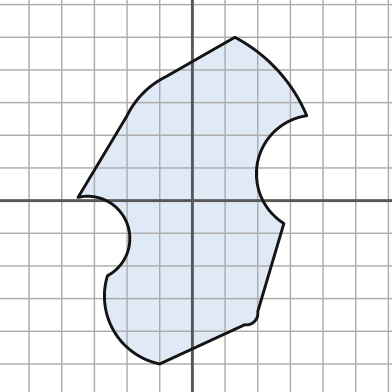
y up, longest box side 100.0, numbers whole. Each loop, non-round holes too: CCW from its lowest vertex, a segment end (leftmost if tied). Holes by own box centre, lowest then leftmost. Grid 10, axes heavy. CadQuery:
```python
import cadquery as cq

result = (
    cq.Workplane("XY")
    .moveTo(-10.0, -50.0)
    .lineTo(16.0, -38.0)
    .threePointArc((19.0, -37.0), (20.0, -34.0))
    .lineTo(28.0, -7.0)
    .threePointArc((20.0, 12.0), (35.0, 26.0))
    .threePointArc((26.0, 40.0), (13.0, 50.0))
    .lineTo(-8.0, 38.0)
    .threePointArc((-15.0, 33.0), (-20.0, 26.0))
    .lineTo(-35.0, 1.0)
    .threePointArc((-20.0, -7.0), (-26.0, -23.0))
    .threePointArc((-24.0, -40.0), (-10.0, -50.0))
    .close()
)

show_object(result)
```